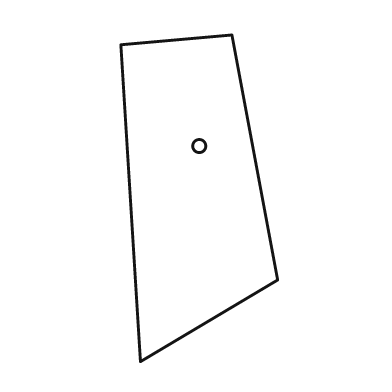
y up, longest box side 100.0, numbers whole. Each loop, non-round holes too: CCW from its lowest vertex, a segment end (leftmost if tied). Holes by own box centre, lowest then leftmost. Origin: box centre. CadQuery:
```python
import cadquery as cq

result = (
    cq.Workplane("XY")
    .moveTo(-18.0, -50.0)
    .lineTo(24.0, -25.0)
    .lineTo(10.0, 50.0)
    .lineTo(-24.0, 47.0)
    .close()
    .moveTo(0.0, 16.0)
    .circle(2.0)
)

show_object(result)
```